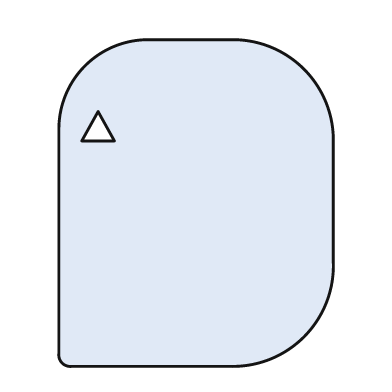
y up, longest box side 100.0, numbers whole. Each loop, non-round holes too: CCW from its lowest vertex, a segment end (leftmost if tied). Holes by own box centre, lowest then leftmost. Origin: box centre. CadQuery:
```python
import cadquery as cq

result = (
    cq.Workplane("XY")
    .moveTo(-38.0, -50.0)
    .lineTo(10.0, -50.0)
    .threePointArc((33.0, -41.0), (42.0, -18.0))
    .lineTo(42.0, 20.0)
    .threePointArc((33.0, 41.0), (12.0, 50.0))
    .lineTo(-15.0, 50.0)
    .threePointArc((-34.0, 42.0), (-42.0, 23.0))
    .lineTo(-42.0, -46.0)
    .threePointArc((-41.0, -49.0), (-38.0, -50.0))
    .close()
    .moveTo(-35.0, 19.0)
    .lineTo(-25.0, 19.0)
    .lineTo(-30.0, 28.0)
    .close()
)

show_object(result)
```